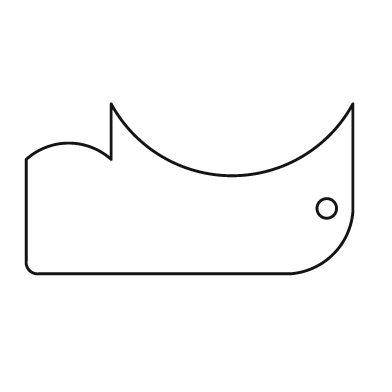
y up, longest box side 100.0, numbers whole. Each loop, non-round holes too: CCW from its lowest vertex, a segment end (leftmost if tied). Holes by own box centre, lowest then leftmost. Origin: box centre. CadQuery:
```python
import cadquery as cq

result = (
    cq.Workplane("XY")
    .moveTo(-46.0, -26.0)
    .lineTo(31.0, -26.0)
    .threePointArc((44.0, -20.0), (50.0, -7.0))
    .lineTo(50.0, 26.0)
    .threePointArc((13.0, 4.0), (-24.0, 26.0))
    .lineTo(-24.0, 9.0)
    .threePointArc((-37.0, 14.0), (-50.0, 9.0))
    .lineTo(-50.0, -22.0)
    .threePointArc((-49.0, -25.0), (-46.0, -26.0))
    .close()
    .moveTo(42.0, -6.0)
    .circle(3.0)
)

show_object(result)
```